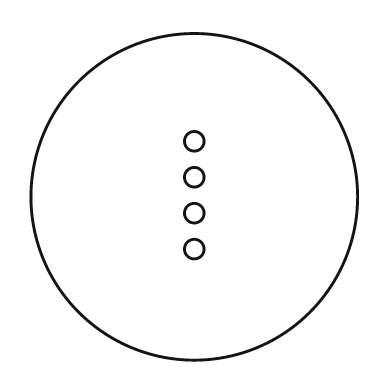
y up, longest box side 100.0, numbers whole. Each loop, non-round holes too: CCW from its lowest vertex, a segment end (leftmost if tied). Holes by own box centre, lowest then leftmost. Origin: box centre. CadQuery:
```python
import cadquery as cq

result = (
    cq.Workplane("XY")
    .moveTo(0.0, 0.0)
    .circle(50.0)
    .moveTo(0.0, -16.0)
    .circle(3.0)
    .moveTo(0.0, -5.0)
    .circle(3.0)
    .moveTo(0.0, 6.0)
    .circle(3.0)
    .moveTo(0.0, 17.0)
    .circle(3.0)
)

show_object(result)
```